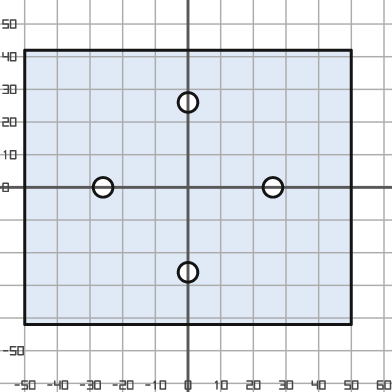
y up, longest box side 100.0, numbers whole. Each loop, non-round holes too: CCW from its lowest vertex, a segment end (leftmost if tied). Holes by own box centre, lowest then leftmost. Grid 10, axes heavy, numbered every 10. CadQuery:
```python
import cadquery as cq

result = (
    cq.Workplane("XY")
    .moveTo(-50.0, -42.0)
    .lineTo(50.0, -42.0)
    .lineTo(50.0, 42.0)
    .lineTo(-50.0, 42.0)
    .close()
    .moveTo(0.0, -26.0)
    .circle(3.0)
    .moveTo(-26.0, 0.0)
    .circle(3.0)
    .moveTo(26.0, 0.0)
    .circle(3.0)
    .moveTo(0.0, 26.0)
    .circle(3.0)
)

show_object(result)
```